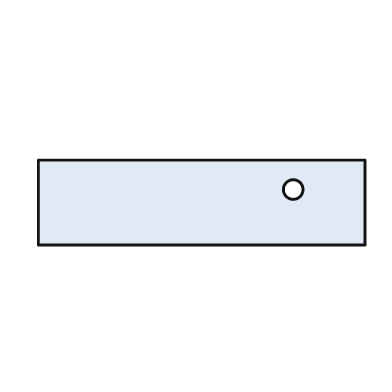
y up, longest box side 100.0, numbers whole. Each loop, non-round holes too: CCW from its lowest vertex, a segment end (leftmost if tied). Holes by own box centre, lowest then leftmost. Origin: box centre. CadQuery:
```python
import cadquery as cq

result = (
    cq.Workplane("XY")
    .moveTo(-50.0, -13.0)
    .lineTo(50.0, -13.0)
    .lineTo(50.0, 13.0)
    .lineTo(-50.0, 13.0)
    .close()
    .moveTo(28.0, 4.0)
    .circle(3.0)
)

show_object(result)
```